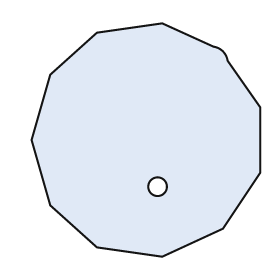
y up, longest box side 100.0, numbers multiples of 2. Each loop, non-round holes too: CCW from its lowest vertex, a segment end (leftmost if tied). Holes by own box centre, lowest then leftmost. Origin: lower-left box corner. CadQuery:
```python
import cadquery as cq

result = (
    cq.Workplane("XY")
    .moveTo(56.0, 0.0)
    .lineTo(82.0, 12.0)
    .lineTo(98.0, 36.0)
    .lineTo(98.0, 64.0)
    .lineTo(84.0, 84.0)
    .threePointArc((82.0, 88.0), (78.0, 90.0))
    .lineTo(56.0, 100.0)
    .lineTo(28.0, 96.0)
    .lineTo(8.0, 78.0)
    .lineTo(0.0, 50.0)
    .lineTo(8.0, 22.0)
    .lineTo(28.0, 4.0)
    .close()
    .moveTo(54.0, 30.0)
    .circle(4.0)
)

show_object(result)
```